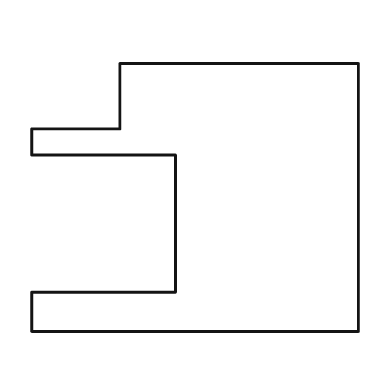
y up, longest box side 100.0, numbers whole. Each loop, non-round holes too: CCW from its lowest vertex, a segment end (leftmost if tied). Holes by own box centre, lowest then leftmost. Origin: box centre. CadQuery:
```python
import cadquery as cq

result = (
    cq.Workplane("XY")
    .moveTo(-50.0, -41.0)
    .lineTo(50.0, -41.0)
    .lineTo(50.0, 41.0)
    .lineTo(-23.0, 41.0)
    .lineTo(-23.0, 21.0)
    .lineTo(-50.0, 21.0)
    .lineTo(-50.0, 13.0)
    .lineTo(-6.0, 13.0)
    .lineTo(-6.0, -29.0)
    .lineTo(-50.0, -29.0)
    .close()
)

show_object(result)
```